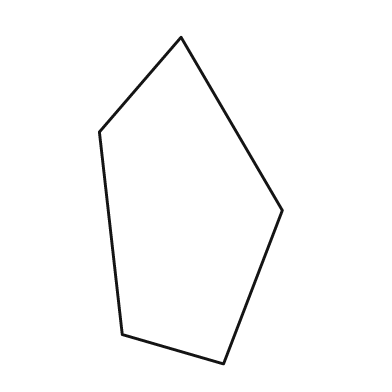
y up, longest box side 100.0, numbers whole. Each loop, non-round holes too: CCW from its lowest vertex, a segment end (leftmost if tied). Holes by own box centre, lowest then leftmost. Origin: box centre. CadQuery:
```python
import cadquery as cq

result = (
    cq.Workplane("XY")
    .moveTo(10.0, -50.0)
    .lineTo(28.0, -3.0)
    .lineTo(-3.0, 50.0)
    .lineTo(-28.0, 21.0)
    .lineTo(-21.0, -41.0)
    .close()
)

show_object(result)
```